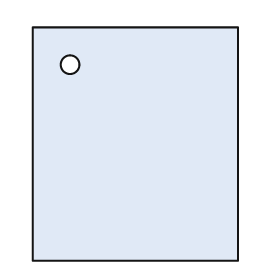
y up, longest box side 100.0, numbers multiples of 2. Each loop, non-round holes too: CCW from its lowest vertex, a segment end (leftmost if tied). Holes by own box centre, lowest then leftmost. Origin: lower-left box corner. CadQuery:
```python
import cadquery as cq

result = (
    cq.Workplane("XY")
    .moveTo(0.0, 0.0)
    .lineTo(88.0, 0.0)
    .lineTo(88.0, 100.0)
    .lineTo(0.0, 100.0)
    .close()
    .moveTo(16.0, 84.0)
    .circle(4.0)
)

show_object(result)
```